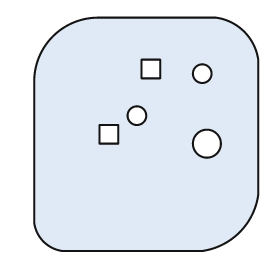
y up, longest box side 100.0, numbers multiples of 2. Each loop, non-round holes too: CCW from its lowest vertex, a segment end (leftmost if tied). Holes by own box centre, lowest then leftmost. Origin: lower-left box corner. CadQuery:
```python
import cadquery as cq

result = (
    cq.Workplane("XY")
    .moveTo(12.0, 0.0)
    .lineTo(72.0, 0.0)
    .threePointArc((88.0, 8.0), (96.0, 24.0))
    .lineTo(96.0, 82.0)
    .threePointArc((90.0, 94.0), (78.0, 100.0))
    .lineTo(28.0, 100.0)
    .threePointArc((8.0, 92.0), (0.0, 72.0))
    .lineTo(0.0, 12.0)
    .threePointArc((4.0, 4.0), (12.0, 0.0))
    .close()
    .moveTo(74.0, 46.0)
    .circle(6.0)
    .moveTo(28.0, 46.0)
    .lineTo(36.0, 46.0)
    .lineTo(36.0, 54.0)
    .lineTo(28.0, 54.0)
    .close()
    .moveTo(44.0, 58.0)
    .circle(4.0)
    .moveTo(72.0, 76.0)
    .circle(4.0)
    .moveTo(46.0, 74.0)
    .lineTo(54.0, 74.0)
    .lineTo(54.0, 82.0)
    .lineTo(46.0, 82.0)
    .close()
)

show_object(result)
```